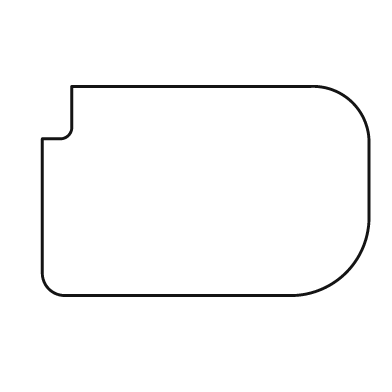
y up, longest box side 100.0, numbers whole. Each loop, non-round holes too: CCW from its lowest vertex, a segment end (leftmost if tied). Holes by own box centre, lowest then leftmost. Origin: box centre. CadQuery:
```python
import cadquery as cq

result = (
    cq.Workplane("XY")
    .moveTo(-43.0, -32.0)
    .lineTo(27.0, -32.0)
    .threePointArc((43.0, -25.0), (50.0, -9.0))
    .lineTo(50.0, 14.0)
    .threePointArc((45.0, 27.0), (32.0, 32.0))
    .lineTo(-41.0, 32.0)
    .lineTo(-41.0, 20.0)
    .threePointArc((-42.0, 17.0), (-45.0, 16.0))
    .lineTo(-50.0, 16.0)
    .lineTo(-50.0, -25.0)
    .threePointArc((-48.0, -30.0), (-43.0, -32.0))
    .close()
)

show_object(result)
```